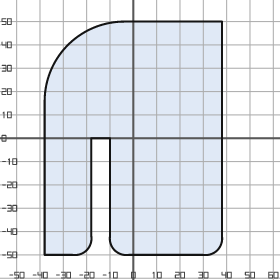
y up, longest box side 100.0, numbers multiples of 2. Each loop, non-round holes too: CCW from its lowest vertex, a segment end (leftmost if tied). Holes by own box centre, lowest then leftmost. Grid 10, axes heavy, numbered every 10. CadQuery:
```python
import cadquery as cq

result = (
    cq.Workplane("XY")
    .moveTo(-38.0, -50.0)
    .lineTo(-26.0, -50.0)
    .threePointArc((-20.0, -48.0), (-18.0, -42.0))
    .lineTo(-18.0, 0.0)
    .lineTo(-10.0, 0.0)
    .lineTo(-10.0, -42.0)
    .threePointArc((-8.0, -48.0), (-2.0, -50.0))
    .lineTo(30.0, -50.0)
    .threePointArc((36.0, -48.0), (38.0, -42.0))
    .lineTo(38.0, 50.0)
    .lineTo(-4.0, 50.0)
    .threePointArc((-28.0, 40.0), (-38.0, 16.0))
    .close()
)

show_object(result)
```